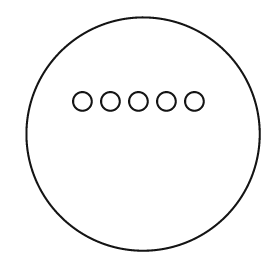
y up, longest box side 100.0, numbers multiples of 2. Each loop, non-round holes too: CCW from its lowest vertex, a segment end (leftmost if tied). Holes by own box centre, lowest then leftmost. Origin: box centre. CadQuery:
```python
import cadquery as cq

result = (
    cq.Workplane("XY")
    .moveTo(0.0, 0.0)
    .circle(50.0)
    .moveTo(-26.0, 14.0)
    .circle(4.0)
    .moveTo(-14.0, 14.0)
    .circle(4.0)
    .moveTo(-2.0, 14.0)
    .circle(4.0)
    .moveTo(10.0, 14.0)
    .circle(4.0)
    .moveTo(22.0, 14.0)
    .circle(4.0)
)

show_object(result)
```